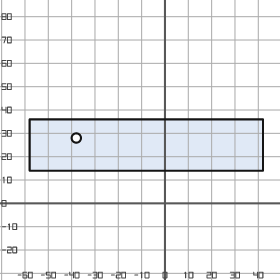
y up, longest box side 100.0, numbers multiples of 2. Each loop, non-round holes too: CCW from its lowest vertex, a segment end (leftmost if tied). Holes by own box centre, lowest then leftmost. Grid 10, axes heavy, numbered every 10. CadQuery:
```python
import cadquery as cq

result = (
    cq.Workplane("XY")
    .moveTo(-58.0, 14.0)
    .lineTo(42.0, 14.0)
    .lineTo(42.0, 36.0)
    .lineTo(-58.0, 36.0)
    .close()
    .moveTo(-38.0, 28.0)
    .circle(2.0)
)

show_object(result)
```